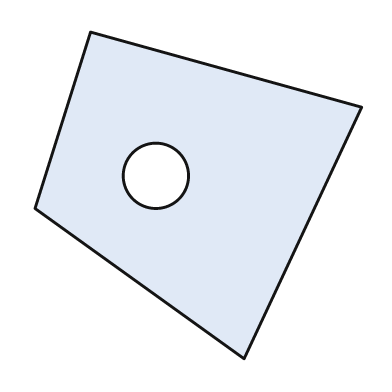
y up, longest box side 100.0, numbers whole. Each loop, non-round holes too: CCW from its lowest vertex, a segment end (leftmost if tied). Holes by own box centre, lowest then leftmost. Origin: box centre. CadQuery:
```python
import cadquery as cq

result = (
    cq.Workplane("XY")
    .moveTo(14.0, -50.0)
    .lineTo(50.0, 27.0)
    .lineTo(-33.0, 50.0)
    .lineTo(-50.0, -4.0)
    .close()
    .moveTo(-13.0, 6.0)
    .circle(10.0)
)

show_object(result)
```